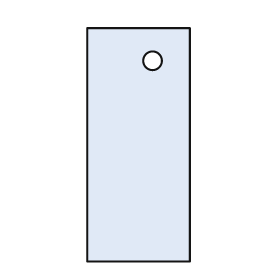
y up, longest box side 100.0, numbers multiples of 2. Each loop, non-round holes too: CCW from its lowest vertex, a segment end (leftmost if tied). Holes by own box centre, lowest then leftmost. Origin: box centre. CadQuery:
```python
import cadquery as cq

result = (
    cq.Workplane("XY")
    .moveTo(-22.0, -50.0)
    .lineTo(22.0, -50.0)
    .lineTo(22.0, 50.0)
    .lineTo(-22.0, 50.0)
    .close()
    .moveTo(6.0, 36.0)
    .circle(4.0)
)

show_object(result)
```